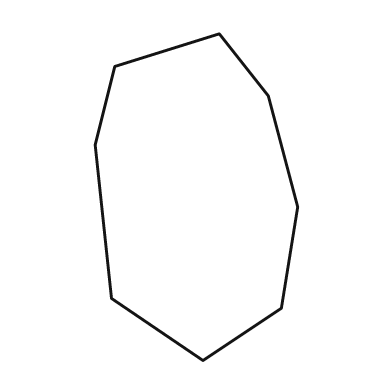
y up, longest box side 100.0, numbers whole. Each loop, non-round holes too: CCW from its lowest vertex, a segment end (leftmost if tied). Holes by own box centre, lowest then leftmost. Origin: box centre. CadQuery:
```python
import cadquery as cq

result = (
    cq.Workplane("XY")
    .moveTo(2.0, -50.0)
    .lineTo(26.0, -34.0)
    .lineTo(31.0, -3.0)
    .lineTo(22.0, 31.0)
    .lineTo(7.0, 50.0)
    .lineTo(-25.0, 40.0)
    .lineTo(-31.0, 16.0)
    .lineTo(-26.0, -31.0)
    .close()
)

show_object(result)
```